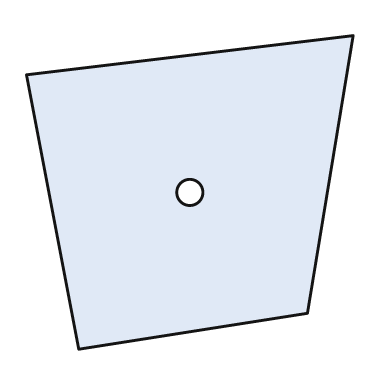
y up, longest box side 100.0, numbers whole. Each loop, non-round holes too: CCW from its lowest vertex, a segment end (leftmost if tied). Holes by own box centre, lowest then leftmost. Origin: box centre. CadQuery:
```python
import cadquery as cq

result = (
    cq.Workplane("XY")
    .moveTo(-34.0, -48.0)
    .lineTo(36.0, -37.0)
    .lineTo(50.0, 48.0)
    .lineTo(-50.0, 36.0)
    .close()
    .moveTo(0.0, 0.0)
    .circle(4.0)
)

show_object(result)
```